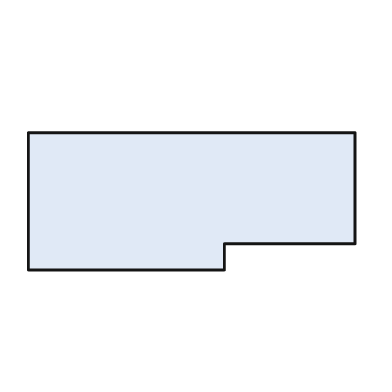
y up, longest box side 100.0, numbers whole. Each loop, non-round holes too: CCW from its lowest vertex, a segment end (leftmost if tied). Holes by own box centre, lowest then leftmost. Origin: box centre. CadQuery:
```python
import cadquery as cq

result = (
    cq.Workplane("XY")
    .moveTo(-50.0, -21.0)
    .lineTo(10.0, -21.0)
    .lineTo(10.0, -13.0)
    .lineTo(50.0, -13.0)
    .lineTo(50.0, 21.0)
    .lineTo(-50.0, 21.0)
    .close()
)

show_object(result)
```